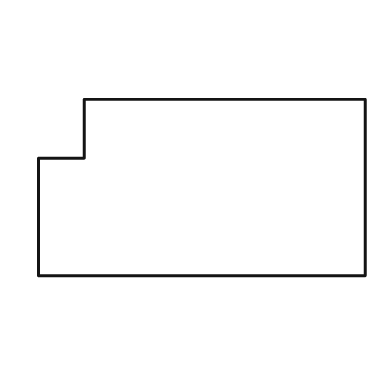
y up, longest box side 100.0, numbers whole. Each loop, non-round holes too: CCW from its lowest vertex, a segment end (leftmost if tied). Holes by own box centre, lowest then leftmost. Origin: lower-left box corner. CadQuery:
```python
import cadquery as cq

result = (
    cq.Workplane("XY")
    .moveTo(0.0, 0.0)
    .lineTo(100.0, 0.0)
    .lineTo(100.0, 54.0)
    .lineTo(14.0, 54.0)
    .lineTo(14.0, 36.0)
    .lineTo(0.0, 36.0)
    .close()
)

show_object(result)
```